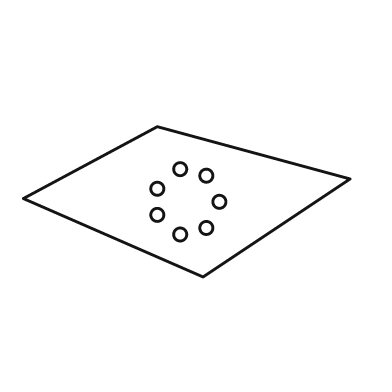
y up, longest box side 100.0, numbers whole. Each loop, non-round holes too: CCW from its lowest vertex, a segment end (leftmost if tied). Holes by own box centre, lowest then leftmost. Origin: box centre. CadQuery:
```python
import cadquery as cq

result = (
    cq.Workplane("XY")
    .moveTo(5.0, -23.0)
    .lineTo(50.0, 7.0)
    .lineTo(-9.0, 23.0)
    .lineTo(-50.0, 1.0)
    .close()
    .moveTo(-2.0, -10.0)
    .circle(2.0)
    .moveTo(6.0, -8.0)
    .circle(2.0)
    .moveTo(-9.0, -4.0)
    .circle(2.0)
    .moveTo(10.0, 0.0)
    .circle(2.0)
    .moveTo(-9.0, 4.0)
    .circle(2.0)
    .moveTo(6.0, 8.0)
    .circle(2.0)
    .moveTo(-2.0, 10.0)
    .circle(2.0)
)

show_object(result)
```